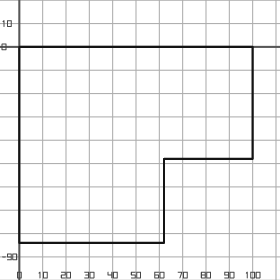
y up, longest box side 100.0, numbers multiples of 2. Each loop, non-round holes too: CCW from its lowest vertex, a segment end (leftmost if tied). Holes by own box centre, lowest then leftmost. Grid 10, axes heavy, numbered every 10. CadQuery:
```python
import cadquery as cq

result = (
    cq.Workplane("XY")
    .moveTo(0.0, -84.0)
    .lineTo(62.0, -84.0)
    .lineTo(62.0, -48.0)
    .lineTo(100.0, -48.0)
    .lineTo(100.0, 0.0)
    .lineTo(0.0, 0.0)
    .close()
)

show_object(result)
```